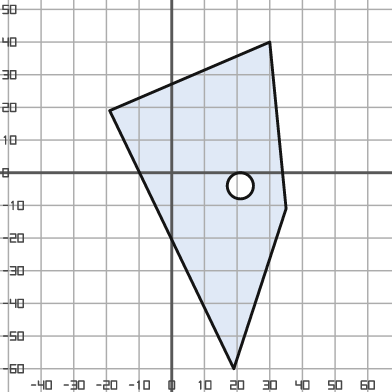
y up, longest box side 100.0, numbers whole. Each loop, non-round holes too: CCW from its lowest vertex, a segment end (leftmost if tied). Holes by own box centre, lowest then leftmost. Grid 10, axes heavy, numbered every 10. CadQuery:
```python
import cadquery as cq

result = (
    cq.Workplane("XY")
    .moveTo(19.0, -60.0)
    .lineTo(35.0, -11.0)
    .lineTo(30.0, 40.0)
    .lineTo(-19.0, 19.0)
    .close()
    .moveTo(21.0, -4.0)
    .circle(4.0)
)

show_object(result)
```